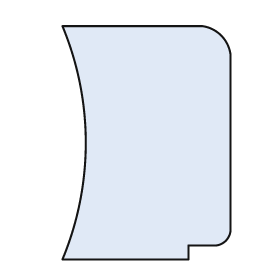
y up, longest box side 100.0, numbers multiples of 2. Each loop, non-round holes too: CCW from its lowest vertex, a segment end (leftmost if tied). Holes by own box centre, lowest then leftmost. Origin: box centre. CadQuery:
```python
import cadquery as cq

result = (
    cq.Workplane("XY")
    .moveTo(-36.0, -50.0)
    .lineTo(18.0, -50.0)
    .lineTo(18.0, -44.0)
    .lineTo(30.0, -44.0)
    .threePointArc((34.0, -42.0), (36.0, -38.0))
    .lineTo(36.0, 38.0)
    .threePointArc((32.0, 46.0), (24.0, 50.0))
    .lineTo(-36.0, 50.0)
    .threePointArc((-26.0, 0.0), (-36.0, -50.0))
    .close()
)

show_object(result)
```